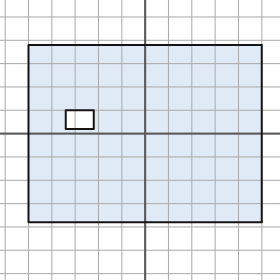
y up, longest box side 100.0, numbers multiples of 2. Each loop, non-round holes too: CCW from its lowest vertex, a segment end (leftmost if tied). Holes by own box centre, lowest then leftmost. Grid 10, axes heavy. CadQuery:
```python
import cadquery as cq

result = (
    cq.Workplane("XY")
    .moveTo(-50.0, -38.0)
    .lineTo(50.0, -38.0)
    .lineTo(50.0, 38.0)
    .lineTo(-50.0, 38.0)
    .close()
    .moveTo(-34.0, 2.0)
    .lineTo(-22.0, 2.0)
    .lineTo(-22.0, 10.0)
    .lineTo(-34.0, 10.0)
    .close()
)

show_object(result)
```